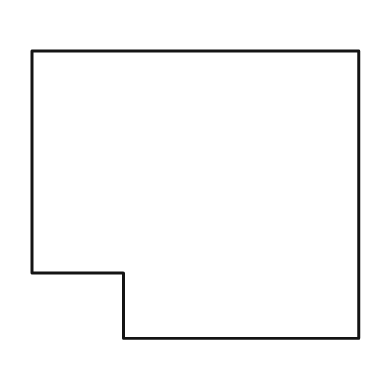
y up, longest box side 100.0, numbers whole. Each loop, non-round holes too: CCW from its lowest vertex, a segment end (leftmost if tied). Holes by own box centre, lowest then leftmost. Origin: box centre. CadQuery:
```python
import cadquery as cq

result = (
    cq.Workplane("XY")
    .moveTo(-22.0, -44.0)
    .lineTo(50.0, -44.0)
    .lineTo(50.0, 44.0)
    .lineTo(-50.0, 44.0)
    .lineTo(-50.0, -24.0)
    .lineTo(-22.0, -24.0)
    .close()
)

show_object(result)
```